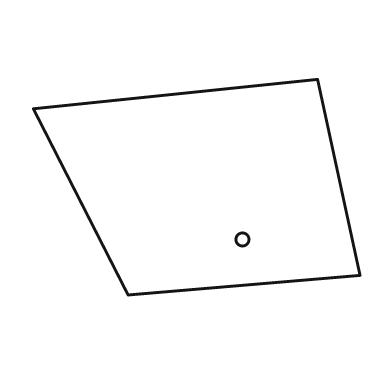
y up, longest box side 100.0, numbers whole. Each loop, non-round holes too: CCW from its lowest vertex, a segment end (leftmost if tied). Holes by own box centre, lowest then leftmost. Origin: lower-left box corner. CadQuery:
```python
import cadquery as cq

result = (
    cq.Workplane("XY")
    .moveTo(29.0, 0.0)
    .lineTo(100.0, 6.0)
    .lineTo(87.0, 66.0)
    .lineTo(0.0, 57.0)
    .close()
    .moveTo(64.0, 17.0)
    .circle(2.0)
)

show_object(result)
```